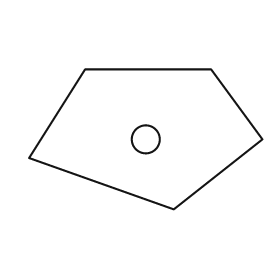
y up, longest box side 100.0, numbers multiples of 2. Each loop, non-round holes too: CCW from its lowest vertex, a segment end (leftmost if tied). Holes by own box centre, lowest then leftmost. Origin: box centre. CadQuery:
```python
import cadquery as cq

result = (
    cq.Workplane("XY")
    .moveTo(12.0, -30.0)
    .lineTo(50.0, 0.0)
    .lineTo(28.0, 30.0)
    .lineTo(-26.0, 30.0)
    .lineTo(-50.0, -8.0)
    .close()
    .moveTo(0.0, 0.0)
    .circle(6.0)
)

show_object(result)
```